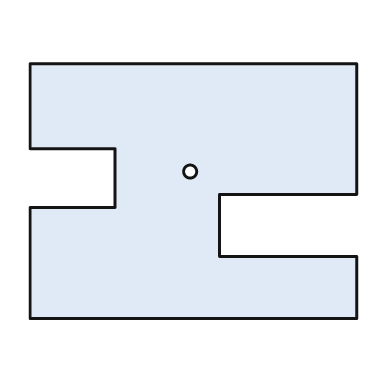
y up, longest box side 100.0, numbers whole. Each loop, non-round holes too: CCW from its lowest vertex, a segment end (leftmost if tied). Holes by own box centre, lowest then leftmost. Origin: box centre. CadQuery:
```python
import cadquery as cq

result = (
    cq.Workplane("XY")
    .moveTo(-50.0, -39.0)
    .lineTo(50.0, -39.0)
    .lineTo(50.0, -20.0)
    .lineTo(8.0, -20.0)
    .lineTo(8.0, -1.0)
    .lineTo(50.0, -1.0)
    .lineTo(50.0, 39.0)
    .lineTo(-50.0, 39.0)
    .lineTo(-50.0, 13.0)
    .lineTo(-24.0, 13.0)
    .lineTo(-24.0, -5.0)
    .lineTo(-50.0, -5.0)
    .close()
    .moveTo(-1.0, 6.0)
    .circle(2.0)
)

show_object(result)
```